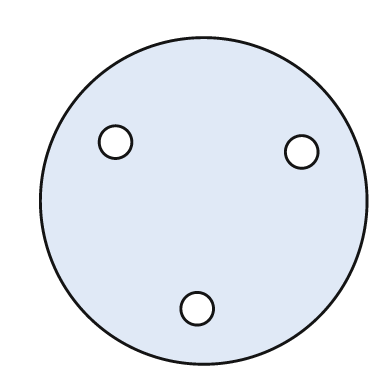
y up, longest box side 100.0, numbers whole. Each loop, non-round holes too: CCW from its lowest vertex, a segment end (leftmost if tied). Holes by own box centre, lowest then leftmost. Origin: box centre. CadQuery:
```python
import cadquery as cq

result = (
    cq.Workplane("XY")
    .moveTo(0.0, 0.0)
    .circle(50.0)
    .moveTo(-2.0, -33.0)
    .circle(5.0)
    .moveTo(30.0, 15.0)
    .circle(5.0)
    .moveTo(-27.0, 18.0)
    .circle(5.0)
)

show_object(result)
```